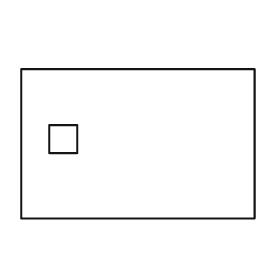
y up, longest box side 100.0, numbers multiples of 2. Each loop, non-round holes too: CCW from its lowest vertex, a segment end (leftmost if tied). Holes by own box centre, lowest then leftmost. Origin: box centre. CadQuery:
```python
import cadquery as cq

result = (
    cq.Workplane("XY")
    .moveTo(-50.0, -32.0)
    .lineTo(50.0, -32.0)
    .lineTo(50.0, 32.0)
    .lineTo(-50.0, 32.0)
    .close()
    .moveTo(-38.0, -4.0)
    .lineTo(-26.0, -4.0)
    .lineTo(-26.0, 8.0)
    .lineTo(-38.0, 8.0)
    .close()
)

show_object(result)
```